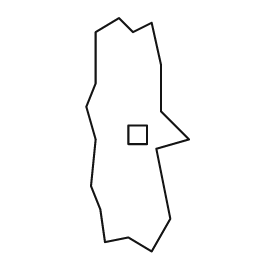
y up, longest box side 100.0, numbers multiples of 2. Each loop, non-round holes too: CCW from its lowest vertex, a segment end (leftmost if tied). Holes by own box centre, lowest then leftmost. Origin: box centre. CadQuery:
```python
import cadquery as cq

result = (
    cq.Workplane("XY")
    .moveTo(6.0, -50.0)
    .lineTo(14.0, -36.0)
    .lineTo(8.0, -6.0)
    .lineTo(22.0, -2.0)
    .lineTo(10.0, 10.0)
    .lineTo(10.0, 30.0)
    .lineTo(6.0, 48.0)
    .lineTo(-2.0, 44.0)
    .lineTo(-8.0, 50.0)
    .lineTo(-18.0, 44.0)
    .lineTo(-18.0, 22.0)
    .lineTo(-22.0, 12.0)
    .lineTo(-18.0, -2.0)
    .lineTo(-20.0, -22.0)
    .lineTo(-16.0, -32.0)
    .lineTo(-14.0, -46.0)
    .lineTo(-4.0, -44.0)
    .close()
    .moveTo(-4.0, -4.0)
    .lineTo(4.0, -4.0)
    .lineTo(4.0, 4.0)
    .lineTo(-4.0, 4.0)
    .close()
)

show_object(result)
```